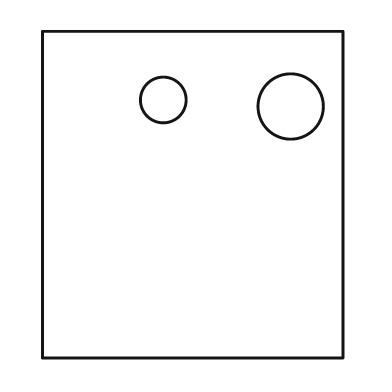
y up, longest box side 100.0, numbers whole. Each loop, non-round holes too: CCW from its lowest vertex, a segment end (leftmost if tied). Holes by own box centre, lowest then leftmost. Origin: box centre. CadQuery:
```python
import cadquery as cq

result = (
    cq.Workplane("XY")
    .moveTo(-46.0, -50.0)
    .lineTo(46.0, -50.0)
    .lineTo(46.0, 50.0)
    .lineTo(-46.0, 50.0)
    .close()
    .moveTo(30.0, 27.0)
    .circle(10.0)
    .moveTo(-9.0, 29.0)
    .circle(7.0)
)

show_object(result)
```